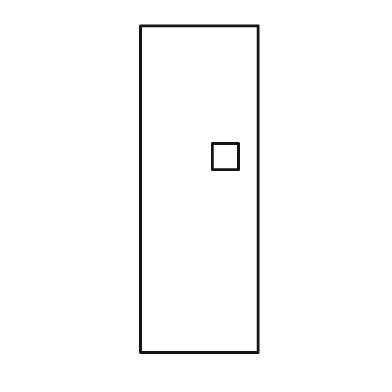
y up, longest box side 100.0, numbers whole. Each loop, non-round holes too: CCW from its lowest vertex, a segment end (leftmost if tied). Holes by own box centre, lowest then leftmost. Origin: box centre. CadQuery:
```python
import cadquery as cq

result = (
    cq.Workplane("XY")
    .moveTo(-18.0, -50.0)
    .lineTo(18.0, -50.0)
    .lineTo(18.0, 50.0)
    .lineTo(-18.0, 50.0)
    .close()
    .moveTo(4.0, 6.0)
    .lineTo(12.0, 6.0)
    .lineTo(12.0, 14.0)
    .lineTo(4.0, 14.0)
    .close()
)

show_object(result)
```